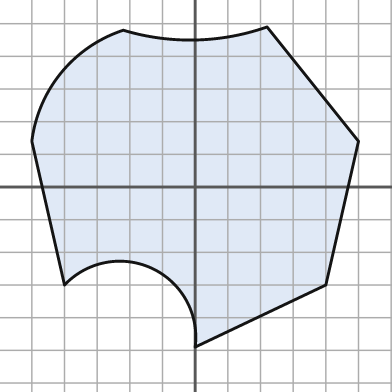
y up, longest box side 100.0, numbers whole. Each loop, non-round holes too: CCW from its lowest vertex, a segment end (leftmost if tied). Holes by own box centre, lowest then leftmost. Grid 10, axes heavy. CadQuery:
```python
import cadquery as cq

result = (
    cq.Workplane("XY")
    .moveTo(0.0, -49.0)
    .lineTo(40.0, -30.0)
    .lineTo(50.0, 14.0)
    .lineTo(22.0, 49.0)
    .threePointArc((0.0, 45.0), (-22.0, 48.0))
    .threePointArc((-41.0, 35.0), (-50.0, 14.0))
    .lineTo(-40.0, -30.0)
    .threePointArc((-13.0, -25.0), (0.0, -49.0))
    .close()
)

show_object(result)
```